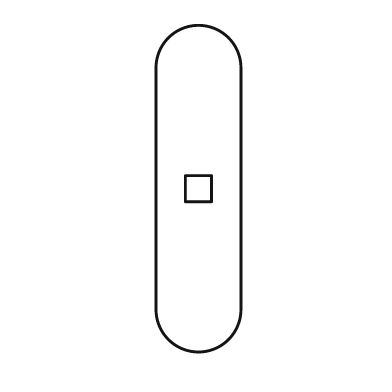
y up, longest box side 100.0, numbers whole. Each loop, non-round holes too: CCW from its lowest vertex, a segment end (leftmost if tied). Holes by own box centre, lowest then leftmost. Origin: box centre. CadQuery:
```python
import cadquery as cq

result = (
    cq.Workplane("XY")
    .moveTo(-13.0, -37.0)
    .threePointArc((0.0, -50.0), (13.0, -37.0))
    .lineTo(13.0, 37.0)
    .threePointArc((0.0, 50.0), (-13.0, 37.0))
    .close()
    .moveTo(-4.0, -4.0)
    .lineTo(4.0, -4.0)
    .lineTo(4.0, 4.0)
    .lineTo(-4.0, 4.0)
    .close()
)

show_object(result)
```